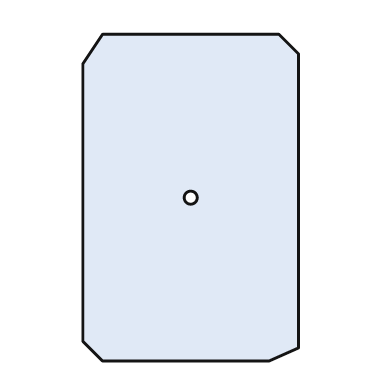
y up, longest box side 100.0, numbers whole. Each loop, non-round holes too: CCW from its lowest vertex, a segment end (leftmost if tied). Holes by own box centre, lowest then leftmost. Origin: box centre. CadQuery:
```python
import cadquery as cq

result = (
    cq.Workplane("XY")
    .moveTo(-27.0, -50.0)
    .lineTo(24.0, -50.0)
    .lineTo(33.0, -46.0)
    .lineTo(33.0, 44.0)
    .lineTo(27.0, 50.0)
    .lineTo(-27.0, 50.0)
    .lineTo(-33.0, 41.0)
    .lineTo(-33.0, -44.0)
    .close()
    .moveTo(0.0, 0.0)
    .circle(2.0)
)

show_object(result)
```